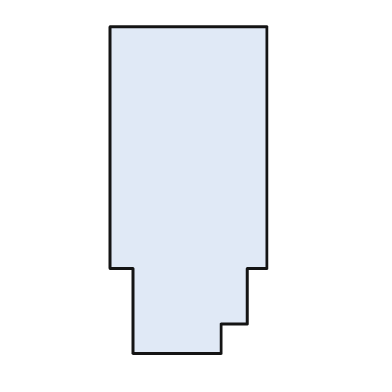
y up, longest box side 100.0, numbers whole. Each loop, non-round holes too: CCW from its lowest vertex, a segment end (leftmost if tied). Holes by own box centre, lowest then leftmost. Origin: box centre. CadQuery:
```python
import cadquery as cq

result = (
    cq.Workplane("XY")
    .moveTo(-17.0, -50.0)
    .lineTo(10.0, -50.0)
    .lineTo(10.0, -41.0)
    .lineTo(18.0, -41.0)
    .lineTo(18.0, -24.0)
    .lineTo(24.0, -24.0)
    .lineTo(24.0, 50.0)
    .lineTo(-24.0, 50.0)
    .lineTo(-24.0, -24.0)
    .lineTo(-17.0, -24.0)
    .close()
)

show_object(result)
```